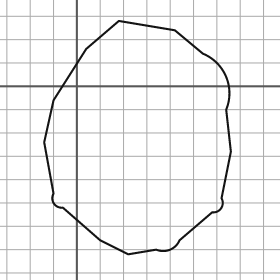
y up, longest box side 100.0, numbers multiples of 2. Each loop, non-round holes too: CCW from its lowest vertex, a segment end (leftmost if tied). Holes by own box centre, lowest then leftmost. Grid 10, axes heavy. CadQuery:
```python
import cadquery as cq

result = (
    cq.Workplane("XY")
    .moveTo(22.0, -72.0)
    .lineTo(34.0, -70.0)
    .threePointArc((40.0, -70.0), (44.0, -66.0))
    .lineTo(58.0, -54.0)
    .threePointArc((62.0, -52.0), (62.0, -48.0))
    .lineTo(66.0, -28.0)
    .lineTo(64.0, -10.0)
    .threePointArc((64.0, 4.0), (54.0, 14.0))
    .lineTo(42.0, 24.0)
    .lineTo(18.0, 28.0)
    .lineTo(4.0, 16.0)
    .lineTo(-10.0, -6.0)
    .lineTo(-14.0, -24.0)
    .lineTo(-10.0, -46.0)
    .threePointArc((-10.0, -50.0), (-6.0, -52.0))
    .lineTo(10.0, -66.0)
    .close()
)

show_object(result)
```